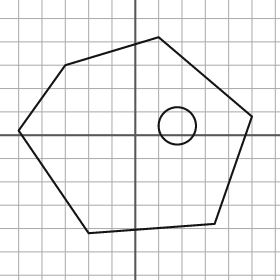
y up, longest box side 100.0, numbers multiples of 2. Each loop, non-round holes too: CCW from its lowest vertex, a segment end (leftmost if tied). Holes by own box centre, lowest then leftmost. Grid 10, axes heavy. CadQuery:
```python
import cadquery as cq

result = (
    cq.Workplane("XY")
    .moveTo(-20.0, -42.0)
    .lineTo(34.0, -38.0)
    .lineTo(50.0, 8.0)
    .lineTo(10.0, 42.0)
    .lineTo(-30.0, 30.0)
    .lineTo(-50.0, 2.0)
    .close()
    .moveTo(18.0, 4.0)
    .circle(8.0)
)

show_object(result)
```